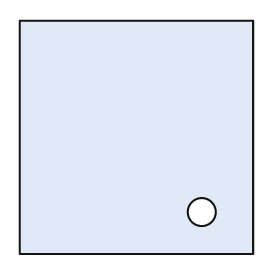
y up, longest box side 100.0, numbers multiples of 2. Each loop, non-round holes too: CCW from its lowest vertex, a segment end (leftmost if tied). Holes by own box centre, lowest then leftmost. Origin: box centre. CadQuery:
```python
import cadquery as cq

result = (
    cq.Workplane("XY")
    .moveTo(-50.0, -50.0)
    .lineTo(50.0, -50.0)
    .lineTo(50.0, 50.0)
    .lineTo(-50.0, 50.0)
    .close()
    .moveTo(28.0, -32.0)
    .circle(6.0)
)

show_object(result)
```